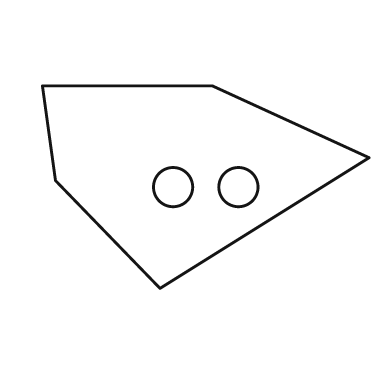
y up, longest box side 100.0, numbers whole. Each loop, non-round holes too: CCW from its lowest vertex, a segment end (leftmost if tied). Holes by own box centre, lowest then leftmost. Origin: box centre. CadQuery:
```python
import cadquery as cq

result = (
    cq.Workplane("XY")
    .moveTo(-14.0, -31.0)
    .lineTo(50.0, 9.0)
    .lineTo(2.0, 31.0)
    .lineTo(-50.0, 31.0)
    .lineTo(-46.0, 2.0)
    .close()
    .moveTo(-10.0, 0.0)
    .circle(6.0)
    .moveTo(10.0, 0.0)
    .circle(6.0)
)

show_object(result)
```